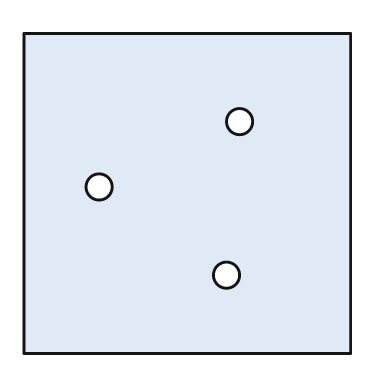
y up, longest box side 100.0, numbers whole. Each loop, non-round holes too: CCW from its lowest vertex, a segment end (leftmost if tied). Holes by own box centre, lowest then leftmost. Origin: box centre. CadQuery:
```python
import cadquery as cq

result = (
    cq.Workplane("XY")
    .moveTo(-50.0, -49.0)
    .lineTo(50.0, -49.0)
    .lineTo(50.0, 49.0)
    .lineTo(-50.0, 49.0)
    .close()
    .moveTo(12.0, -25.0)
    .circle(4.0)
    .moveTo(-27.0, 2.0)
    .circle(4.0)
    .moveTo(16.0, 22.0)
    .circle(4.0)
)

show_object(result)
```